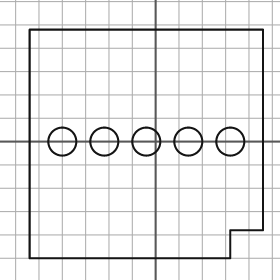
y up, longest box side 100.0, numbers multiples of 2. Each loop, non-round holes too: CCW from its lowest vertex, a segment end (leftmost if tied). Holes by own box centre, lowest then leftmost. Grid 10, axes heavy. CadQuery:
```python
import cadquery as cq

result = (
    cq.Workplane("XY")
    .moveTo(-54.0, -50.0)
    .lineTo(32.0, -50.0)
    .lineTo(32.0, -38.0)
    .lineTo(46.0, -38.0)
    .lineTo(46.0, 48.0)
    .lineTo(-54.0, 48.0)
    .close()
    .moveTo(-40.0, 0.0)
    .circle(6.0)
    .moveTo(-22.0, 0.0)
    .circle(6.0)
    .moveTo(-4.0, 0.0)
    .circle(6.0)
    .moveTo(14.0, 0.0)
    .circle(6.0)
    .moveTo(32.0, 0.0)
    .circle(6.0)
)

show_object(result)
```